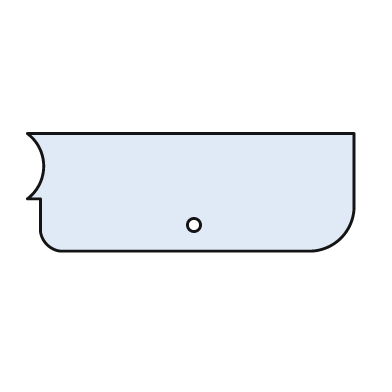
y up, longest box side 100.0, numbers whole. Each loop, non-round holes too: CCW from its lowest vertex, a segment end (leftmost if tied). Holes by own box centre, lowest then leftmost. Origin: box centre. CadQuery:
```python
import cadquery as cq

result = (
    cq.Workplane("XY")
    .moveTo(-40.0, -18.0)
    .lineTo(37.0, -18.0)
    .threePointArc((46.0, -14.0), (50.0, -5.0))
    .lineTo(50.0, 18.0)
    .lineTo(-50.0, 18.0)
    .threePointArc((-45.0, 8.0), (-50.0, -2.0))
    .lineTo(-46.0, -2.0)
    .lineTo(-46.0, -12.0)
    .threePointArc((-44.0, -16.0), (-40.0, -18.0))
    .close()
    .moveTo(1.0, -10.0)
    .circle(2.0)
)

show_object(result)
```